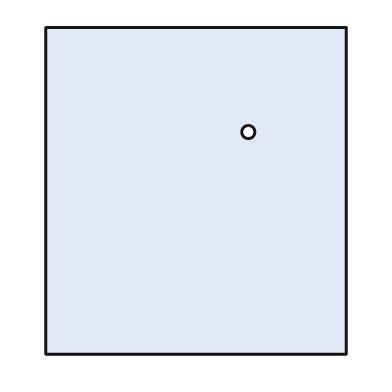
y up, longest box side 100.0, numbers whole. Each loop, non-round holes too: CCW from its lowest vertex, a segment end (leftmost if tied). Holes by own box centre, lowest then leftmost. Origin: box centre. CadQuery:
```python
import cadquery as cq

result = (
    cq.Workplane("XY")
    .moveTo(-46.0, -50.0)
    .lineTo(46.0, -50.0)
    .lineTo(46.0, 50.0)
    .lineTo(-46.0, 50.0)
    .close()
    .moveTo(16.0, 18.0)
    .circle(2.0)
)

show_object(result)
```